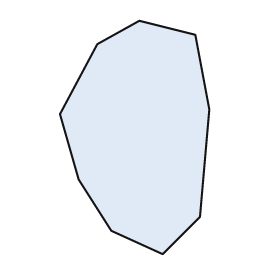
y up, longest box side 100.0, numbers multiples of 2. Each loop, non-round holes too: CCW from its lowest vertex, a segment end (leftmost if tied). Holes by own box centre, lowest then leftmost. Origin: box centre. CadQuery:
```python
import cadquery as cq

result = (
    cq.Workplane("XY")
    .moveTo(12.0, -50.0)
    .lineTo(28.0, -34.0)
    .lineTo(32.0, 12.0)
    .lineTo(26.0, 44.0)
    .lineTo(2.0, 50.0)
    .lineTo(-16.0, 40.0)
    .lineTo(-32.0, 10.0)
    .lineTo(-24.0, -18.0)
    .lineTo(-10.0, -40.0)
    .close()
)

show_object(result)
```